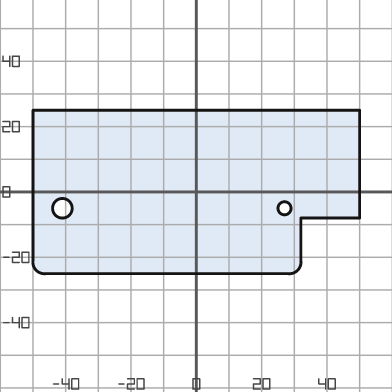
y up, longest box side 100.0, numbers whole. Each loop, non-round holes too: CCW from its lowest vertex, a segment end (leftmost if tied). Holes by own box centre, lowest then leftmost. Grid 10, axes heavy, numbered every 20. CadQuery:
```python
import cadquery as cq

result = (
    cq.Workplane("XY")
    .moveTo(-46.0, -25.0)
    .lineTo(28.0, -25.0)
    .threePointArc((31.0, -24.0), (32.0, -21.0))
    .lineTo(32.0, -8.0)
    .lineTo(50.0, -8.0)
    .lineTo(50.0, 25.0)
    .lineTo(-50.0, 25.0)
    .lineTo(-50.0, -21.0)
    .threePointArc((-49.0, -24.0), (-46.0, -25.0))
    .close()
    .moveTo(-41.0, -5.0)
    .circle(3.0)
    .moveTo(27.0, -5.0)
    .circle(2.0)
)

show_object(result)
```